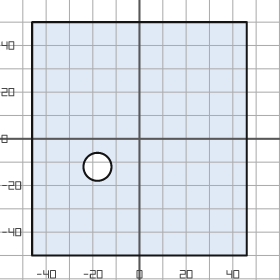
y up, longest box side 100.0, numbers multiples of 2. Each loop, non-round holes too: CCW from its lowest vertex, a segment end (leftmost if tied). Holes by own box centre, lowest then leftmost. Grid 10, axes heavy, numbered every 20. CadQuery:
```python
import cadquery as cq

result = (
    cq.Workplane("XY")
    .moveTo(-46.0, -50.0)
    .lineTo(46.0, -50.0)
    .lineTo(46.0, 50.0)
    .lineTo(-46.0, 50.0)
    .close()
    .moveTo(-18.0, -12.0)
    .circle(6.0)
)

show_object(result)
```